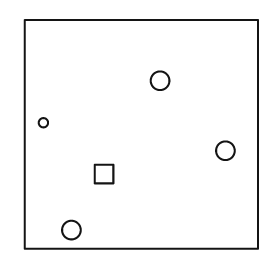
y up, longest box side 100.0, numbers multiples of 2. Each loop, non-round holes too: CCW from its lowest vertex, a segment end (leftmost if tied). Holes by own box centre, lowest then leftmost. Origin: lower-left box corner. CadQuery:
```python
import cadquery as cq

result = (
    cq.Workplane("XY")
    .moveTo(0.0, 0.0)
    .lineTo(100.0, 0.0)
    .lineTo(100.0, 98.0)
    .lineTo(0.0, 98.0)
    .close()
    .moveTo(20.0, 8.0)
    .circle(4.0)
    .moveTo(30.0, 28.0)
    .lineTo(38.0, 28.0)
    .lineTo(38.0, 36.0)
    .lineTo(30.0, 36.0)
    .close()
    .moveTo(86.0, 42.0)
    .circle(4.0)
    .moveTo(8.0, 54.0)
    .circle(2.0)
    .moveTo(58.0, 72.0)
    .circle(4.0)
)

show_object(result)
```